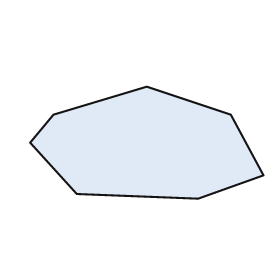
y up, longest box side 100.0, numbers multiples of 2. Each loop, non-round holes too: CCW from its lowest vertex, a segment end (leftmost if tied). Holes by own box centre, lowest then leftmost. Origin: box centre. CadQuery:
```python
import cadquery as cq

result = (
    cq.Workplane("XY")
    .moveTo(22.0, -24.0)
    .lineTo(50.0, -14.0)
    .lineTo(36.0, 12.0)
    .lineTo(0.0, 24.0)
    .lineTo(-40.0, 12.0)
    .lineTo(-50.0, 0.0)
    .lineTo(-30.0, -22.0)
    .close()
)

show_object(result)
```